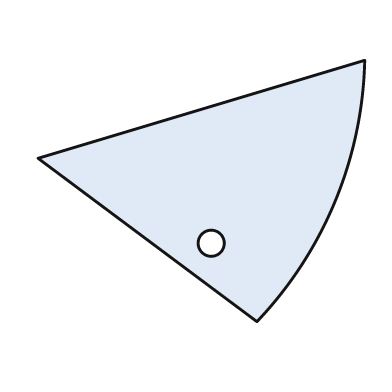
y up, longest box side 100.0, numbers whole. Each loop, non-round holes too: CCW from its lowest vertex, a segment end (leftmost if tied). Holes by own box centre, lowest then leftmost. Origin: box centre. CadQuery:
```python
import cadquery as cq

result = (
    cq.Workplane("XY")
    .moveTo(17.0, -40.0)
    .threePointArc((41.0, -3.0), (50.0, 40.0))
    .lineTo(-50.0, 10.0)
    .close()
    .moveTo(3.0, -16.0)
    .circle(4.0)
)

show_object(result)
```